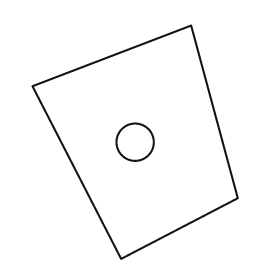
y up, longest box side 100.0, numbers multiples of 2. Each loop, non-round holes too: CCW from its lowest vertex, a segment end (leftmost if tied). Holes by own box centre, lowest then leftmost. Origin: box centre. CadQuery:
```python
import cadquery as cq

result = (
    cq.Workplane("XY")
    .moveTo(-6.0, -50.0)
    .lineTo(44.0, -24.0)
    .lineTo(24.0, 50.0)
    .lineTo(-44.0, 24.0)
    .close()
    .moveTo(0.0, 0.0)
    .circle(8.0)
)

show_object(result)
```